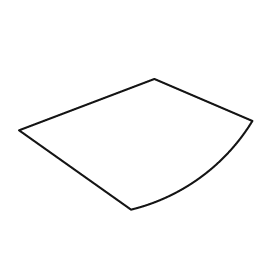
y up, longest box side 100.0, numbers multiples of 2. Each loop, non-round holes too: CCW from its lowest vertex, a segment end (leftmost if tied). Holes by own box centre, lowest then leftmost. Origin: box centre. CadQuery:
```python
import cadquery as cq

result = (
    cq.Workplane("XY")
    .moveTo(-2.0, -28.0)
    .threePointArc((28.0, -14.0), (50.0, 10.0))
    .lineTo(8.0, 28.0)
    .lineTo(-50.0, 6.0)
    .close()
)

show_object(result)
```